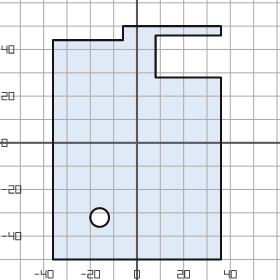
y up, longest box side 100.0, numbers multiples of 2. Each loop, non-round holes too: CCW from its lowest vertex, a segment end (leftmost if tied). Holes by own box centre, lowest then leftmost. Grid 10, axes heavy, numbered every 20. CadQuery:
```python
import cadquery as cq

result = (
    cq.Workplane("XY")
    .moveTo(-36.0, -50.0)
    .lineTo(36.0, -50.0)
    .lineTo(36.0, 28.0)
    .lineTo(8.0, 28.0)
    .lineTo(8.0, 46.0)
    .lineTo(36.0, 46.0)
    .lineTo(36.0, 50.0)
    .lineTo(-6.0, 50.0)
    .lineTo(-6.0, 44.0)
    .lineTo(-36.0, 44.0)
    .close()
    .moveTo(-16.0, -32.0)
    .circle(4.0)
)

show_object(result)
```